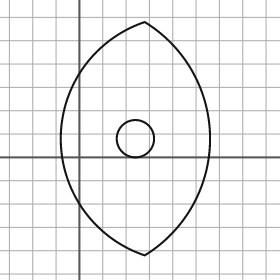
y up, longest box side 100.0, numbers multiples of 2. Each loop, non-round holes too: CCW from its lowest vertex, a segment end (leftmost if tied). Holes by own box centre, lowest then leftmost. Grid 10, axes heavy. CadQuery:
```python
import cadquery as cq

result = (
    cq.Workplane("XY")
    .moveTo(28.0, -42.0)
    .threePointArc((56.0, 8.0), (28.0, 58.0))
    .threePointArc((-8.0, 8.0), (28.0, -42.0))
    .close()
    .moveTo(24.0, 8.0)
    .circle(8.0)
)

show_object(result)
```